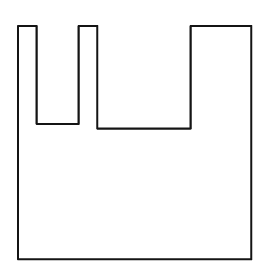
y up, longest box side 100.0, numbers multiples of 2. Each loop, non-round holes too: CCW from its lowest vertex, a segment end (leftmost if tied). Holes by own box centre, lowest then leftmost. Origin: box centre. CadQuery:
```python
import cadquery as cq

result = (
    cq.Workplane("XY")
    .moveTo(-50.0, -50.0)
    .lineTo(50.0, -50.0)
    .lineTo(50.0, 50.0)
    .lineTo(24.0, 50.0)
    .lineTo(24.0, 6.0)
    .lineTo(-16.0, 6.0)
    .lineTo(-16.0, 50.0)
    .lineTo(-24.0, 50.0)
    .lineTo(-24.0, 8.0)
    .lineTo(-42.0, 8.0)
    .lineTo(-42.0, 50.0)
    .lineTo(-50.0, 50.0)
    .close()
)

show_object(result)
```